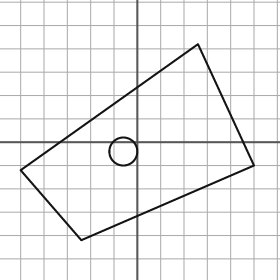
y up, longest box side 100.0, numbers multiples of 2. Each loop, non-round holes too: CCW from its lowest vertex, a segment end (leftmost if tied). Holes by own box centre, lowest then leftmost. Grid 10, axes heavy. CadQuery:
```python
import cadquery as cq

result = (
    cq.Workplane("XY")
    .moveTo(-24.0, -42.0)
    .lineTo(50.0, -10.0)
    .lineTo(26.0, 42.0)
    .lineTo(-50.0, -12.0)
    .close()
    .moveTo(-6.0, -4.0)
    .circle(6.0)
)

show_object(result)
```